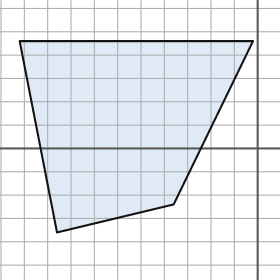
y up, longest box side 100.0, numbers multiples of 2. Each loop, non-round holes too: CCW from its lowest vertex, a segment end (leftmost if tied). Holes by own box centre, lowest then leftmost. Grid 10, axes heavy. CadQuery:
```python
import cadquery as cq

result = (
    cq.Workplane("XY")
    .moveTo(-86.0, -36.0)
    .lineTo(-36.0, -24.0)
    .lineTo(-2.0, 46.0)
    .lineTo(-102.0, 46.0)
    .close()
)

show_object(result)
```